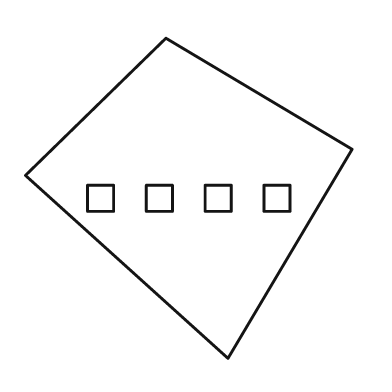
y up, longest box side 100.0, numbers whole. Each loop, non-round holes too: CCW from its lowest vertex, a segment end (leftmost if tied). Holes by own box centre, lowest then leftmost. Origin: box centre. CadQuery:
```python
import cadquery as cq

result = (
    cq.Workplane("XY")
    .moveTo(12.0, -49.0)
    .lineTo(50.0, 15.0)
    .lineTo(-7.0, 49.0)
    .lineTo(-50.0, 7.0)
    .close()
    .moveTo(-31.0, -4.0)
    .lineTo(-23.0, -4.0)
    .lineTo(-23.0, 4.0)
    .lineTo(-31.0, 4.0)
    .close()
    .moveTo(-13.0, -4.0)
    .lineTo(-5.0, -4.0)
    .lineTo(-5.0, 4.0)
    .lineTo(-13.0, 4.0)
    .close()
    .moveTo(5.0, -4.0)
    .lineTo(13.0, -4.0)
    .lineTo(13.0, 4.0)
    .lineTo(5.0, 4.0)
    .close()
    .moveTo(23.0, -4.0)
    .lineTo(31.0, -4.0)
    .lineTo(31.0, 4.0)
    .lineTo(23.0, 4.0)
    .close()
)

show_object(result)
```